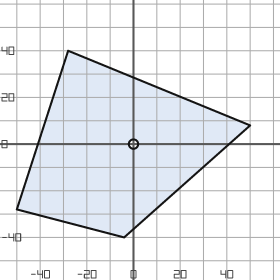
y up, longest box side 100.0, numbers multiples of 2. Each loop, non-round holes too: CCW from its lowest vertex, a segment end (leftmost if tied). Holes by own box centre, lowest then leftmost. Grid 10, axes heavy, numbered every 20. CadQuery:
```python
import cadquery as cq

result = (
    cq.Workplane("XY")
    .moveTo(-4.0, -40.0)
    .lineTo(50.0, 8.0)
    .lineTo(-28.0, 40.0)
    .lineTo(-50.0, -28.0)
    .close()
    .moveTo(0.0, 0.0)
    .circle(2.0)
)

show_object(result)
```